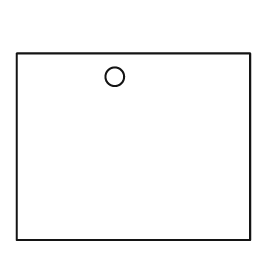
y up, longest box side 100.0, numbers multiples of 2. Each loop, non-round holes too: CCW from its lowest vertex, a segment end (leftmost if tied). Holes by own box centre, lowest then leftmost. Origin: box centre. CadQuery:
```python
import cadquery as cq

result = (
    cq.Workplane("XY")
    .moveTo(-50.0, -40.0)
    .lineTo(50.0, -40.0)
    .lineTo(50.0, 40.0)
    .lineTo(-50.0, 40.0)
    .close()
    .moveTo(-8.0, 30.0)
    .circle(4.0)
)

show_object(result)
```